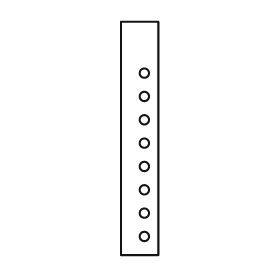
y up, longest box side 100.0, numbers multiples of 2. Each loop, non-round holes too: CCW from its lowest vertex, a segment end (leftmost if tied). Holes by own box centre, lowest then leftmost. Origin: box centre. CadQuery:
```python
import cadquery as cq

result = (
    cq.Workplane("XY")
    .moveTo(-8.0, -50.0)
    .lineTo(8.0, -50.0)
    .lineTo(8.0, 50.0)
    .lineTo(-8.0, 50.0)
    .close()
    .moveTo(2.0, -42.0)
    .circle(2.0)
    .moveTo(2.0, -32.0)
    .circle(2.0)
    .moveTo(2.0, -22.0)
    .circle(2.0)
    .moveTo(2.0, -12.0)
    .circle(2.0)
    .moveTo(2.0, -2.0)
    .circle(2.0)
    .moveTo(2.0, 8.0)
    .circle(2.0)
    .moveTo(2.0, 18.0)
    .circle(2.0)
    .moveTo(2.0, 28.0)
    .circle(2.0)
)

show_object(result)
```